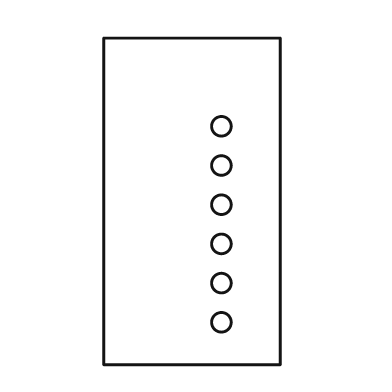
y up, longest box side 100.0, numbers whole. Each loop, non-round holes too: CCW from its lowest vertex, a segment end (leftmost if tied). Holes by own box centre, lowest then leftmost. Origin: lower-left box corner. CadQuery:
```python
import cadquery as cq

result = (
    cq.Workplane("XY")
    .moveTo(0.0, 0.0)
    .lineTo(54.0, 0.0)
    .lineTo(54.0, 100.0)
    .lineTo(0.0, 100.0)
    .close()
    .moveTo(36.0, 13.0)
    .circle(3.0)
    .moveTo(36.0, 25.0)
    .circle(3.0)
    .moveTo(36.0, 37.0)
    .circle(3.0)
    .moveTo(36.0, 49.0)
    .circle(3.0)
    .moveTo(36.0, 61.0)
    .circle(3.0)
    .moveTo(36.0, 73.0)
    .circle(3.0)
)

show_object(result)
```